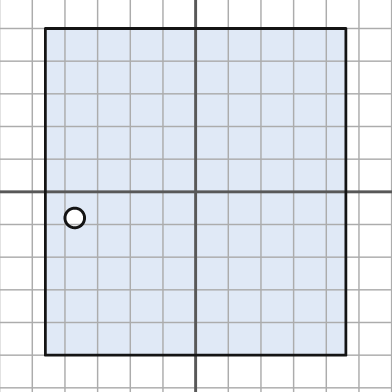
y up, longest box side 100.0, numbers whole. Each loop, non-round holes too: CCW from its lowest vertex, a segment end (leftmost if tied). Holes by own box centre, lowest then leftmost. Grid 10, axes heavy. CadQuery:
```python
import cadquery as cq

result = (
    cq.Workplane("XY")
    .moveTo(-46.0, -50.0)
    .lineTo(46.0, -50.0)
    .lineTo(46.0, 50.0)
    .lineTo(-46.0, 50.0)
    .close()
    .moveTo(-37.0, -8.0)
    .circle(3.0)
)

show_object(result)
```